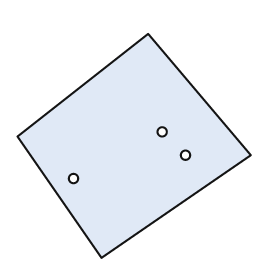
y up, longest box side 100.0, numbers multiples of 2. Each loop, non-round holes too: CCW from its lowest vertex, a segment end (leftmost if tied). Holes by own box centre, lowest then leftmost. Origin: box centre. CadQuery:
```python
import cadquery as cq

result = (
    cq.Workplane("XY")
    .moveTo(-14.0, -48.0)
    .lineTo(50.0, -4.0)
    .lineTo(6.0, 48.0)
    .lineTo(-50.0, 4.0)
    .close()
    .moveTo(-26.0, -14.0)
    .circle(2.0)
    .moveTo(22.0, -4.0)
    .circle(2.0)
    .moveTo(12.0, 6.0)
    .circle(2.0)
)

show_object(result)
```